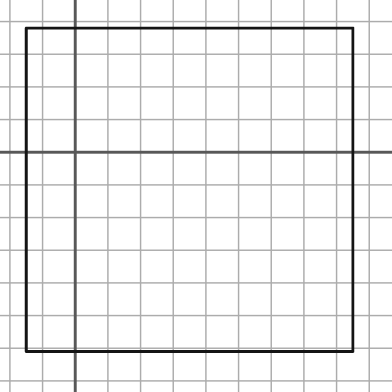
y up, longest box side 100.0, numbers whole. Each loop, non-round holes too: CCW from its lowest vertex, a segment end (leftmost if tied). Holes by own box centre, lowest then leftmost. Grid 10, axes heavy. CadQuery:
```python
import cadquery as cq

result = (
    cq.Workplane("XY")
    .moveTo(-15.0, -61.0)
    .lineTo(85.0, -61.0)
    .lineTo(85.0, 38.0)
    .lineTo(-15.0, 38.0)
    .close()
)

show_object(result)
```